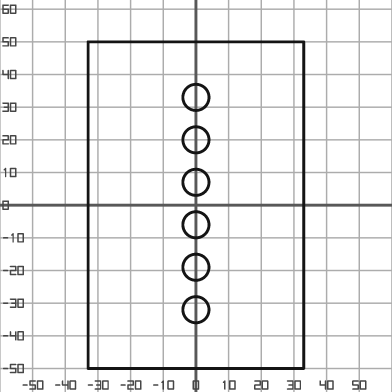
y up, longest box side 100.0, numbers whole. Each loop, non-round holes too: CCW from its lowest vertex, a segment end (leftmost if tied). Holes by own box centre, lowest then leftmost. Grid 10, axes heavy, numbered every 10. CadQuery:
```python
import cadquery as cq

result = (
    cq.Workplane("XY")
    .moveTo(-33.0, -50.0)
    .lineTo(33.0, -50.0)
    .lineTo(33.0, 50.0)
    .lineTo(-33.0, 50.0)
    .close()
    .moveTo(0.0, -32.0)
    .circle(4.0)
    .moveTo(0.0, -19.0)
    .circle(4.0)
    .moveTo(0.0, -6.0)
    .circle(4.0)
    .moveTo(0.0, 7.0)
    .circle(4.0)
    .moveTo(0.0, 20.0)
    .circle(4.0)
    .moveTo(0.0, 33.0)
    .circle(4.0)
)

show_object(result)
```